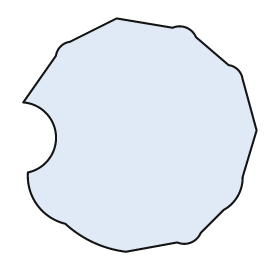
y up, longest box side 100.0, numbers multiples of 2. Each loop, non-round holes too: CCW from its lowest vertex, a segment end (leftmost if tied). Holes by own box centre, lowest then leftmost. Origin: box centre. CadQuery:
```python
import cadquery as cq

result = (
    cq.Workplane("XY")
    .moveTo(-6.0, -50.0)
    .lineTo(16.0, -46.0)
    .threePointArc((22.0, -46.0), (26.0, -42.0))
    .lineTo(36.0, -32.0)
    .threePointArc((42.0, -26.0), (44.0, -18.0))
    .lineTo(50.0, 2.0)
    .lineTo(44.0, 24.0)
    .threePointArc((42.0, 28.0), (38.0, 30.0))
    .lineTo(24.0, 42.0)
    .threePointArc((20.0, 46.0), (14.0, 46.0))
    .lineTo(-10.0, 50.0)
    .lineTo(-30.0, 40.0)
    .threePointArc((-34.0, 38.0), (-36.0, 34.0))
    .lineTo(-50.0, 14.0)
    .threePointArc((-36.0, 0.0), (-48.0, -16.0))
    .threePointArc((-44.0, -30.0), (-32.0, -38.0))
    .threePointArc((-20.0, -46.0), (-6.0, -50.0))
    .close()
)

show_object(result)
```